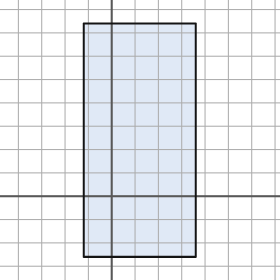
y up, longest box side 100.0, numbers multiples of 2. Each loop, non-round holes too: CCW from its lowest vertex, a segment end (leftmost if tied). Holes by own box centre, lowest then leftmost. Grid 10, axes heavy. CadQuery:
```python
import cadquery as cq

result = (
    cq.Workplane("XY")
    .moveTo(-12.0, -26.0)
    .lineTo(36.0, -26.0)
    .lineTo(36.0, 74.0)
    .lineTo(-12.0, 74.0)
    .close()
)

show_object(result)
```